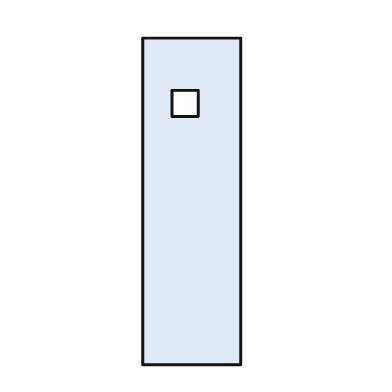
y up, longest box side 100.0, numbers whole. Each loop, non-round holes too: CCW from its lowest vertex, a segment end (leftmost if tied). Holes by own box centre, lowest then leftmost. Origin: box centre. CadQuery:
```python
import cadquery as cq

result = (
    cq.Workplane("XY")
    .moveTo(-15.0, -50.0)
    .lineTo(15.0, -50.0)
    .lineTo(15.0, 50.0)
    .lineTo(-15.0, 50.0)
    .close()
    .moveTo(-6.0, 26.0)
    .lineTo(2.0, 26.0)
    .lineTo(2.0, 34.0)
    .lineTo(-6.0, 34.0)
    .close()
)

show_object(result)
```